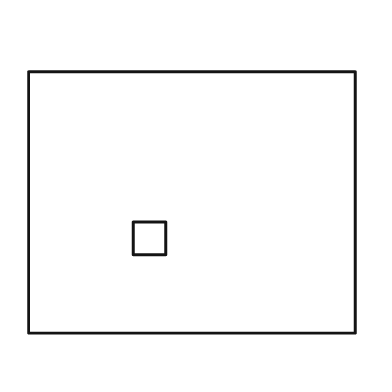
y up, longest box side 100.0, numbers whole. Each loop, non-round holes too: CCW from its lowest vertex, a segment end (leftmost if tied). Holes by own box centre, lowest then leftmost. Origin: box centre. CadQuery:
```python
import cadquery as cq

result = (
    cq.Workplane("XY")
    .moveTo(-50.0, -40.0)
    .lineTo(50.0, -40.0)
    .lineTo(50.0, 40.0)
    .lineTo(-50.0, 40.0)
    .close()
    .moveTo(-18.0, -16.0)
    .lineTo(-8.0, -16.0)
    .lineTo(-8.0, -6.0)
    .lineTo(-18.0, -6.0)
    .close()
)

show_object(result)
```